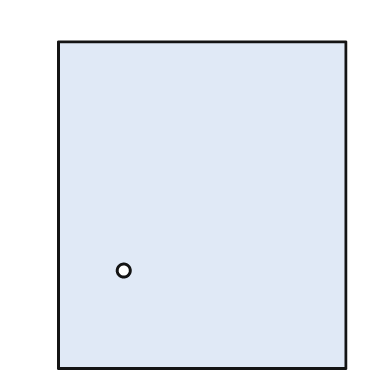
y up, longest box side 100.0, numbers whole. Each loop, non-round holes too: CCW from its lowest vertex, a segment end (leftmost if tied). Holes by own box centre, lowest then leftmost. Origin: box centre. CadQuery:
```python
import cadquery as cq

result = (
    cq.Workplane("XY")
    .moveTo(-44.0, -50.0)
    .lineTo(44.0, -50.0)
    .lineTo(44.0, 50.0)
    .lineTo(-44.0, 50.0)
    .close()
    .moveTo(-24.0, -20.0)
    .circle(2.0)
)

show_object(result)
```